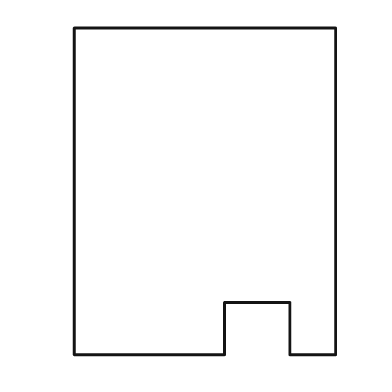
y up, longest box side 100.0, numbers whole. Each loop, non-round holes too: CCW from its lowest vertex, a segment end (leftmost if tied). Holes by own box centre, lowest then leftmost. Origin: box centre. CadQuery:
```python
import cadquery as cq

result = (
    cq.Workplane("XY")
    .moveTo(-40.0, -50.0)
    .lineTo(6.0, -50.0)
    .lineTo(6.0, -34.0)
    .lineTo(26.0, -34.0)
    .lineTo(26.0, -50.0)
    .lineTo(40.0, -50.0)
    .lineTo(40.0, 50.0)
    .lineTo(-40.0, 50.0)
    .close()
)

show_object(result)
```